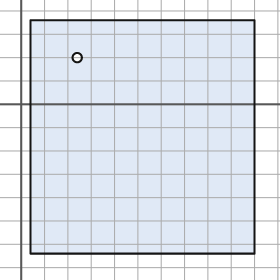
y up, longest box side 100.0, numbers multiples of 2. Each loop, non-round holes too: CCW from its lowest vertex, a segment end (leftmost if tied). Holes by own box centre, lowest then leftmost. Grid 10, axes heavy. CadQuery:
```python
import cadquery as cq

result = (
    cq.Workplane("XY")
    .moveTo(4.0, -64.0)
    .lineTo(100.0, -64.0)
    .lineTo(100.0, 36.0)
    .lineTo(4.0, 36.0)
    .close()
    .moveTo(24.0, 20.0)
    .circle(2.0)
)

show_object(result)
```